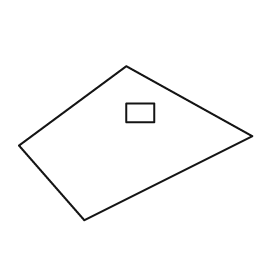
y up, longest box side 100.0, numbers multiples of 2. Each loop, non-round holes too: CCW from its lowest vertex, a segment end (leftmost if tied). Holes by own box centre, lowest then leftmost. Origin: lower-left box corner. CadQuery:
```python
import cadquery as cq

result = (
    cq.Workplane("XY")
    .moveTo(28.0, 0.0)
    .lineTo(100.0, 36.0)
    .lineTo(46.0, 66.0)
    .lineTo(0.0, 32.0)
    .close()
    .moveTo(46.0, 42.0)
    .lineTo(58.0, 42.0)
    .lineTo(58.0, 50.0)
    .lineTo(46.0, 50.0)
    .close()
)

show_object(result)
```